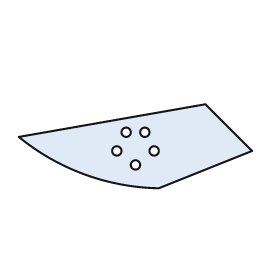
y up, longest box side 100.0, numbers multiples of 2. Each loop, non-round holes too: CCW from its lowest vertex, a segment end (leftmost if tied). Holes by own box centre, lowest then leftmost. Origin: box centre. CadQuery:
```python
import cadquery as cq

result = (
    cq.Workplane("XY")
    .moveTo(10.0, -18.0)
    .lineTo(50.0, -2.0)
    .lineTo(30.0, 18.0)
    .lineTo(-50.0, 4.0)
    .threePointArc((-22.0, -12.0), (10.0, -18.0))
    .close()
    .moveTo(0.0, -8.0)
    .circle(2.0)
    .moveTo(-8.0, -2.0)
    .circle(2.0)
    .moveTo(8.0, -2.0)
    .circle(2.0)
    .moveTo(-4.0, 6.0)
    .circle(2.0)
    .moveTo(4.0, 6.0)
    .circle(2.0)
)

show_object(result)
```